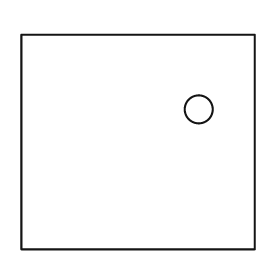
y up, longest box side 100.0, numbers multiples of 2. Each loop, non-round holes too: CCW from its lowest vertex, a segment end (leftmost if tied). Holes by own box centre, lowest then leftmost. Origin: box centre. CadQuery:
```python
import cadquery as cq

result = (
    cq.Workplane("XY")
    .moveTo(-50.0, -46.0)
    .lineTo(50.0, -46.0)
    .lineTo(50.0, 46.0)
    .lineTo(-50.0, 46.0)
    .close()
    .moveTo(26.0, 14.0)
    .circle(6.0)
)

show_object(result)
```